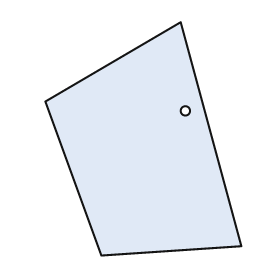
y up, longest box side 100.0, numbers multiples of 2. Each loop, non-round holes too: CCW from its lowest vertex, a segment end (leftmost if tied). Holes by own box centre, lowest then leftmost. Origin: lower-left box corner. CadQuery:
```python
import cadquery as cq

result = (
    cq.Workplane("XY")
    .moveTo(24.0, 0.0)
    .lineTo(84.0, 4.0)
    .lineTo(58.0, 100.0)
    .lineTo(0.0, 66.0)
    .close()
    .moveTo(60.0, 62.0)
    .circle(2.0)
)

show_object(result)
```